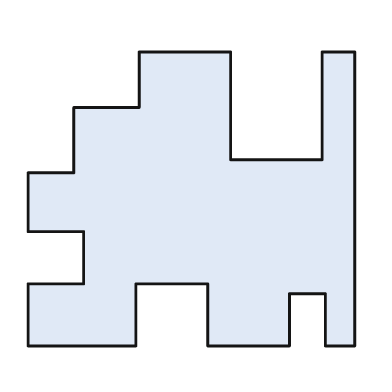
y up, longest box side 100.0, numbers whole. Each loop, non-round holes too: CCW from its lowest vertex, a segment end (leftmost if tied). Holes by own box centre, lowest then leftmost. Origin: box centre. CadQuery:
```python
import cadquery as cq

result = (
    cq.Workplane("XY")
    .moveTo(-50.0, -45.0)
    .lineTo(-17.0, -45.0)
    .lineTo(-17.0, -26.0)
    .lineTo(5.0, -26.0)
    .lineTo(5.0, -45.0)
    .lineTo(30.0, -45.0)
    .lineTo(30.0, -29.0)
    .lineTo(41.0, -29.0)
    .lineTo(41.0, -45.0)
    .lineTo(50.0, -45.0)
    .lineTo(50.0, 45.0)
    .lineTo(40.0, 45.0)
    .lineTo(40.0, 12.0)
    .lineTo(12.0, 12.0)
    .lineTo(12.0, 45.0)
    .lineTo(-16.0, 45.0)
    .lineTo(-16.0, 28.0)
    .lineTo(-36.0, 28.0)
    .lineTo(-36.0, 8.0)
    .lineTo(-50.0, 8.0)
    .lineTo(-50.0, -10.0)
    .lineTo(-33.0, -10.0)
    .lineTo(-33.0, -26.0)
    .lineTo(-50.0, -26.0)
    .close()
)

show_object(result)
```